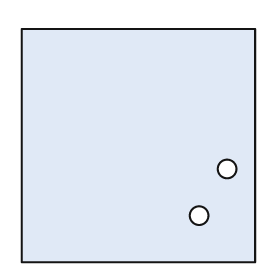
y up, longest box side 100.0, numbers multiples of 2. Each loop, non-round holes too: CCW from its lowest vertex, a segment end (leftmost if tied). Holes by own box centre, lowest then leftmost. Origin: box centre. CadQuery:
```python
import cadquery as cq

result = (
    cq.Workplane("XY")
    .moveTo(-50.0, -50.0)
    .lineTo(50.0, -50.0)
    .lineTo(50.0, 50.0)
    .lineTo(-50.0, 50.0)
    .close()
    .moveTo(26.0, -30.0)
    .circle(4.0)
    .moveTo(38.0, -10.0)
    .circle(4.0)
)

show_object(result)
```